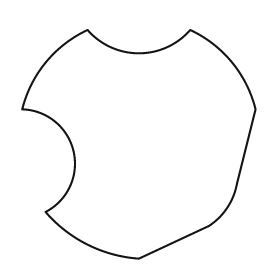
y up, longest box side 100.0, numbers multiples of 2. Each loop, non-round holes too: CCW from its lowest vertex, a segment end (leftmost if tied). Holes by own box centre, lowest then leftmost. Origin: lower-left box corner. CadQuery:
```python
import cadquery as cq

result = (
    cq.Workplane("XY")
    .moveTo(50.0, 0.0)
    .lineTo(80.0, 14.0)
    .threePointArc((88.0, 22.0), (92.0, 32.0))
    .lineTo(100.0, 64.0)
    .threePointArc((90.0, 84.0), (72.0, 98.0))
    .threePointArc((50.0, 88.0), (28.0, 98.0))
    .threePointArc((10.0, 84.0), (0.0, 64.0))
    .threePointArc((22.0, 46.0), (10.0, 20.0))
    .threePointArc((28.0, 6.0), (50.0, 0.0))
    .close()
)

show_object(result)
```